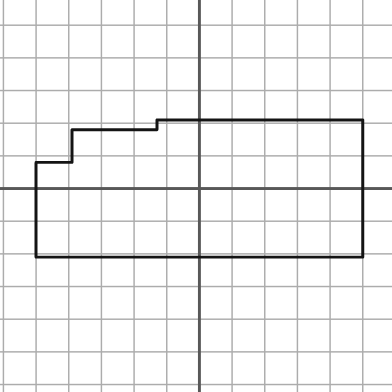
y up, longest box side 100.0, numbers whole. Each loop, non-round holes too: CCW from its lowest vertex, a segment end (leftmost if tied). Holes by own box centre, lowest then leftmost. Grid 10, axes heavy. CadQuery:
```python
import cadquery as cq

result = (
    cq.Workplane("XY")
    .moveTo(-50.0, -21.0)
    .lineTo(50.0, -21.0)
    .lineTo(50.0, 21.0)
    .lineTo(-13.0, 21.0)
    .lineTo(-13.0, 18.0)
    .lineTo(-39.0, 18.0)
    .lineTo(-39.0, 8.0)
    .lineTo(-50.0, 8.0)
    .close()
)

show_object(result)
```